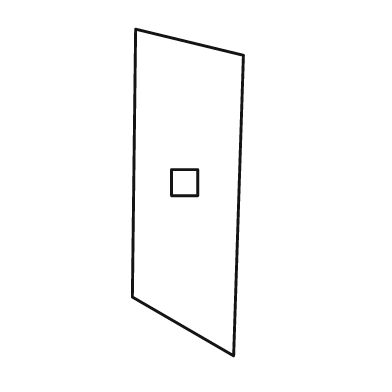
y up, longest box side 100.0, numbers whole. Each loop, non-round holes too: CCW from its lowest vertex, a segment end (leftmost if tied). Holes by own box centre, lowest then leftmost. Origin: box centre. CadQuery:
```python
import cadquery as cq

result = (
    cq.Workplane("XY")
    .moveTo(14.0, -50.0)
    .lineTo(17.0, 42.0)
    .lineTo(-16.0, 50.0)
    .lineTo(-17.0, -32.0)
    .close()
    .moveTo(-5.0, -1.0)
    .lineTo(3.0, -1.0)
    .lineTo(3.0, 7.0)
    .lineTo(-5.0, 7.0)
    .close()
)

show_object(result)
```